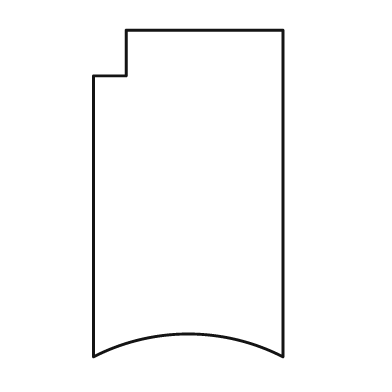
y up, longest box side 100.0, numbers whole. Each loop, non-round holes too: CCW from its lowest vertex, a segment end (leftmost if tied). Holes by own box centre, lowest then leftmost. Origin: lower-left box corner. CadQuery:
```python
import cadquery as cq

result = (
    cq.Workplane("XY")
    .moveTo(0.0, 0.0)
    .threePointArc((29.0, 7.0), (58.0, 0.0))
    .lineTo(58.0, 100.0)
    .lineTo(10.0, 100.0)
    .lineTo(10.0, 86.0)
    .lineTo(0.0, 86.0)
    .close()
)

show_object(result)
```